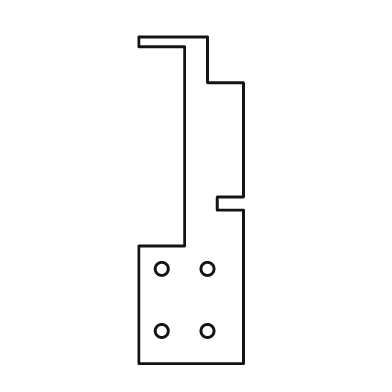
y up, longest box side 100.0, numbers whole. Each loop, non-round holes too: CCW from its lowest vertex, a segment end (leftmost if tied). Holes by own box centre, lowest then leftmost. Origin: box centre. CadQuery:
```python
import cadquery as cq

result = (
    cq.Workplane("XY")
    .moveTo(-16.0, -50.0)
    .lineTo(16.0, -50.0)
    .lineTo(16.0, -3.0)
    .lineTo(8.0, -3.0)
    .lineTo(8.0, 1.0)
    .lineTo(16.0, 1.0)
    .lineTo(16.0, 36.0)
    .lineTo(5.0, 36.0)
    .lineTo(5.0, 50.0)
    .lineTo(-16.0, 50.0)
    .lineTo(-16.0, 47.0)
    .lineTo(-2.0, 47.0)
    .lineTo(-2.0, -14.0)
    .lineTo(-16.0, -14.0)
    .close()
    .moveTo(-9.0, -40.0)
    .circle(2.0)
    .moveTo(5.0, -40.0)
    .circle(2.0)
    .moveTo(-9.0, -21.0)
    .circle(2.0)
    .moveTo(5.0, -21.0)
    .circle(2.0)
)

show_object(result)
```